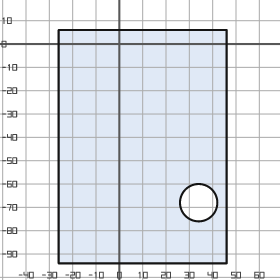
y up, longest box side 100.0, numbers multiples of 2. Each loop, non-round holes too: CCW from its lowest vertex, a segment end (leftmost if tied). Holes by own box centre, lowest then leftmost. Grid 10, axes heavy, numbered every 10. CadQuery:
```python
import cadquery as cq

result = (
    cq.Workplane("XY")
    .moveTo(-26.0, -94.0)
    .lineTo(46.0, -94.0)
    .lineTo(46.0, 6.0)
    .lineTo(-26.0, 6.0)
    .close()
    .moveTo(34.0, -68.0)
    .circle(8.0)
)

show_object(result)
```